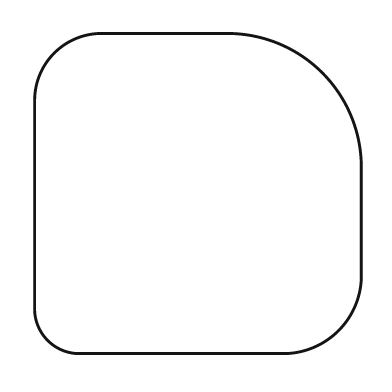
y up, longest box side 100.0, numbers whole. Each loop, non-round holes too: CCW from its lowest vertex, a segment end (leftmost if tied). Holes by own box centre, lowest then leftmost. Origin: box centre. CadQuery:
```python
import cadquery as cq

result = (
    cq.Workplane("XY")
    .moveTo(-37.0, -49.0)
    .lineTo(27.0, -49.0)
    .threePointArc((43.0, -42.0), (50.0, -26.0))
    .lineTo(50.0, 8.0)
    .threePointArc((38.0, 37.0), (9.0, 49.0))
    .lineTo(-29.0, 49.0)
    .threePointArc((-44.0, 43.0), (-50.0, 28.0))
    .lineTo(-50.0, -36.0)
    .threePointArc((-46.0, -45.0), (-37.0, -49.0))
    .close()
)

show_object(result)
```